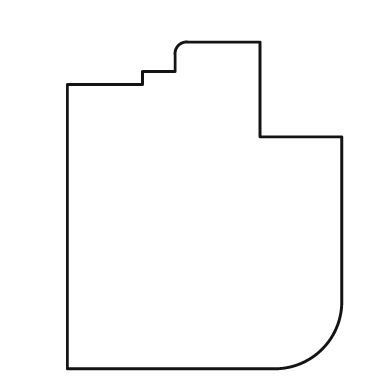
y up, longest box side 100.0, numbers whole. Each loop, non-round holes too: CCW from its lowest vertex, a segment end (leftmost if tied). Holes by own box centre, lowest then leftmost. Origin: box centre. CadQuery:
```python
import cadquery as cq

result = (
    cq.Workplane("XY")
    .moveTo(-42.0, -50.0)
    .lineTo(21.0, -50.0)
    .threePointArc((36.0, -44.0), (42.0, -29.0))
    .lineTo(42.0, 21.0)
    .lineTo(17.0, 21.0)
    .lineTo(17.0, 50.0)
    .lineTo(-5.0, 50.0)
    .threePointArc((-8.0, 49.0), (-9.0, 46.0))
    .lineTo(-9.0, 41.0)
    .lineTo(-19.0, 41.0)
    .lineTo(-19.0, 37.0)
    .lineTo(-42.0, 37.0)
    .close()
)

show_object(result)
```